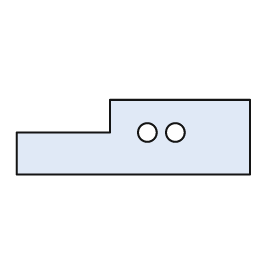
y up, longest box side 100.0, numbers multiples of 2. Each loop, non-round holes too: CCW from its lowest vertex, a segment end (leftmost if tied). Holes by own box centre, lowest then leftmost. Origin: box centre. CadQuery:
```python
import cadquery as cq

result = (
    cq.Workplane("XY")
    .moveTo(-50.0, -16.0)
    .lineTo(50.0, -16.0)
    .lineTo(50.0, 16.0)
    .lineTo(-10.0, 16.0)
    .lineTo(-10.0, 2.0)
    .lineTo(-50.0, 2.0)
    .close()
    .moveTo(6.0, 2.0)
    .circle(4.0)
    .moveTo(18.0, 2.0)
    .circle(4.0)
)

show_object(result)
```